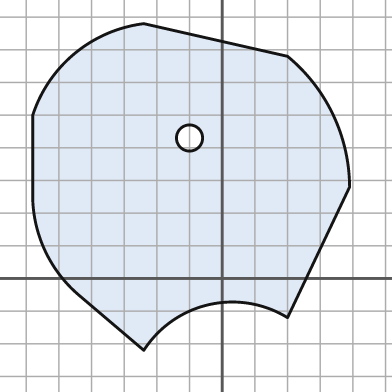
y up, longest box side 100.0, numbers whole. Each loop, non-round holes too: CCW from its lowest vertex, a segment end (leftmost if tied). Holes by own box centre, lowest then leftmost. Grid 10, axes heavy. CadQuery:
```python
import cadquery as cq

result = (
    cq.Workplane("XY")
    .moveTo(-24.0, -22.0)
    .threePointArc((-4.0, -8.0), (20.0, -12.0))
    .lineTo(39.0, 28.0)
    .threePointArc((34.0, 50.0), (20.0, 68.0))
    .lineTo(-24.0, 78.0)
    .threePointArc((-45.0, 69.0), (-58.0, 50.0))
    .lineTo(-58.0, 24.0)
    .threePointArc((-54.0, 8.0), (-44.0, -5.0))
    .close()
    .moveTo(-10.0, 43.0)
    .circle(4.0)
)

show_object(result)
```